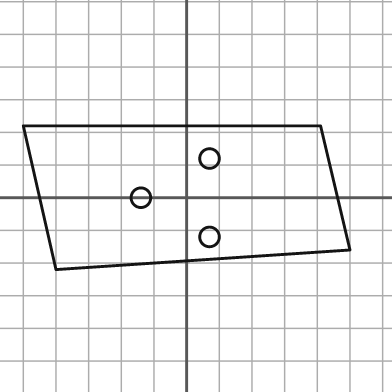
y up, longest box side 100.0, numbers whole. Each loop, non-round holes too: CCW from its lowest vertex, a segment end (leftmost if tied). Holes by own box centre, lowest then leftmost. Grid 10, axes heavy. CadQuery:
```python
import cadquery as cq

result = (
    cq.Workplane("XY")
    .moveTo(-40.0, -22.0)
    .lineTo(50.0, -16.0)
    .lineTo(41.0, 22.0)
    .lineTo(-50.0, 22.0)
    .close()
    .moveTo(7.0, -12.0)
    .circle(3.0)
    .moveTo(-14.0, 0.0)
    .circle(3.0)
    .moveTo(7.0, 12.0)
    .circle(3.0)
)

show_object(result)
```